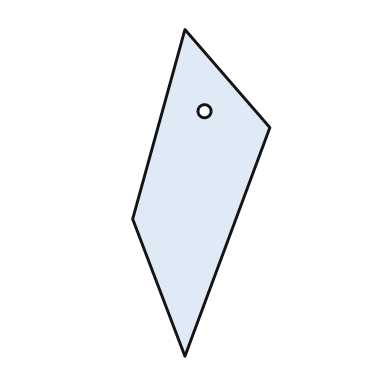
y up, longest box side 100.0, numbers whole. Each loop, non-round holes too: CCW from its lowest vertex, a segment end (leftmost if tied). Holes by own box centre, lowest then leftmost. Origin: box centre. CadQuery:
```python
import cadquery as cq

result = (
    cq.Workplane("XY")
    .moveTo(-5.0, -50.0)
    .lineTo(21.0, 20.0)
    .lineTo(-5.0, 50.0)
    .lineTo(-21.0, -8.0)
    .close()
    .moveTo(1.0, 25.0)
    .circle(2.0)
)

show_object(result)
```